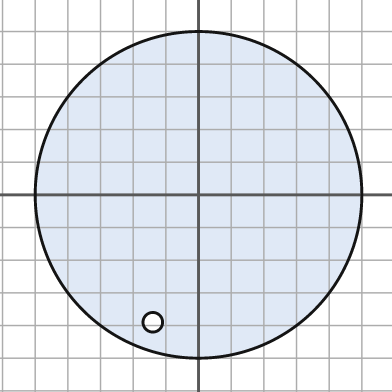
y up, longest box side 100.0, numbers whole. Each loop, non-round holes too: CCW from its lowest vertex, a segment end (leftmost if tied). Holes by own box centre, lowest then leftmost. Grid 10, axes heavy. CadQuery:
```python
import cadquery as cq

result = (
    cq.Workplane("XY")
    .moveTo(0.0, 0.0)
    .circle(50.0)
    .moveTo(-14.0, -39.0)
    .circle(3.0)
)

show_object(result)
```